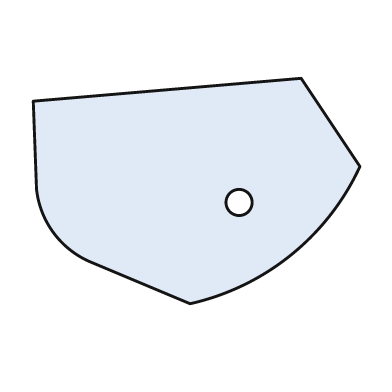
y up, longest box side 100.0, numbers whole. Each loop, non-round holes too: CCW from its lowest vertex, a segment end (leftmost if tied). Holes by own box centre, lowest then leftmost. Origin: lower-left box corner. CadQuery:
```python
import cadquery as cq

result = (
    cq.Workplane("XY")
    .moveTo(48.0, 0.0)
    .threePointArc((79.0, 15.0), (100.0, 42.0))
    .lineTo(82.0, 69.0)
    .lineTo(0.0, 62.0)
    .lineTo(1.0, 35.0)
    .threePointArc((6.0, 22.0), (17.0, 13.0))
    .close()
    .moveTo(63.0, 31.0)
    .circle(4.0)
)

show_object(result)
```